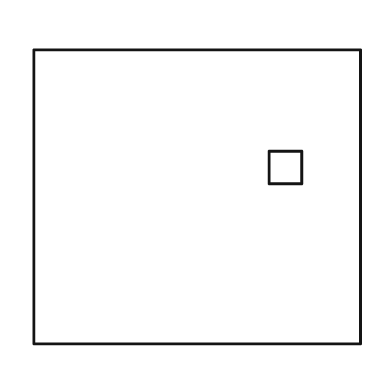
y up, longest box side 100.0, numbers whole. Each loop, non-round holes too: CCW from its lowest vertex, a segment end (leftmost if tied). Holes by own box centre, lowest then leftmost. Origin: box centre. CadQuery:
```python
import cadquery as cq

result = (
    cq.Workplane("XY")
    .moveTo(-50.0, -45.0)
    .lineTo(50.0, -45.0)
    .lineTo(50.0, 45.0)
    .lineTo(-50.0, 45.0)
    .close()
    .moveTo(22.0, 4.0)
    .lineTo(32.0, 4.0)
    .lineTo(32.0, 14.0)
    .lineTo(22.0, 14.0)
    .close()
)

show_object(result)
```